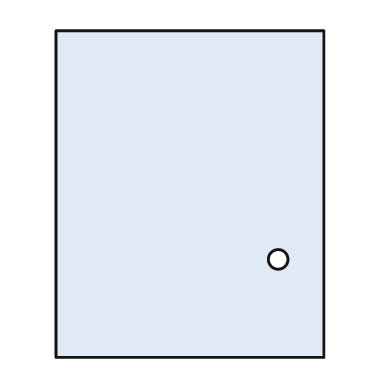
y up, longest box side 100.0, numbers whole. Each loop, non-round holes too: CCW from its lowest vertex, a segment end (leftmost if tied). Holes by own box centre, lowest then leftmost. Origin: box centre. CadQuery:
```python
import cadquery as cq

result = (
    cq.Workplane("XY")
    .moveTo(-41.0, -50.0)
    .lineTo(41.0, -50.0)
    .lineTo(41.0, 50.0)
    .lineTo(-41.0, 50.0)
    .close()
    .moveTo(27.0, -20.0)
    .circle(3.0)
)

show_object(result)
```